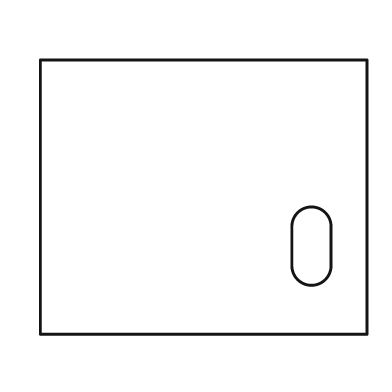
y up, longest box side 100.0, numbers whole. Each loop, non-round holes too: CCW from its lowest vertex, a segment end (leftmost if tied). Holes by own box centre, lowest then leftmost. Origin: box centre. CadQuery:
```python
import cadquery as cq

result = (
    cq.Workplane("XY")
    .moveTo(-50.0, -42.0)
    .lineTo(50.0, -42.0)
    .lineTo(50.0, 42.0)
    .lineTo(-50.0, 42.0)
    .close()
    .moveTo(27.0, -21.0)
    .threePointArc((33.0, -27.0), (39.0, -21.0))
    .lineTo(39.0, -9.0)
    .threePointArc((33.0, -3.0), (27.0, -9.0))
    .close()
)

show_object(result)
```